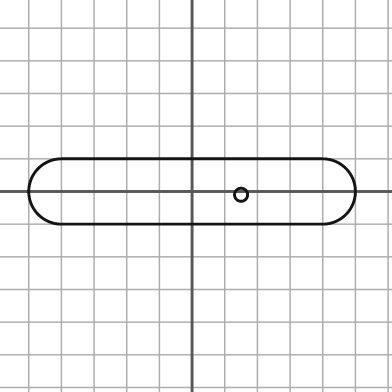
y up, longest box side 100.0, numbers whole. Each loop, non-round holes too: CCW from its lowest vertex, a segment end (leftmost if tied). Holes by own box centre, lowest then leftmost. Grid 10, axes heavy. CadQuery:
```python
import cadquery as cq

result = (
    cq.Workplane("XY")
    .moveTo(-40.0, -10.0)
    .lineTo(40.0, -10.0)
    .threePointArc((50.0, 0.0), (40.0, 10.0))
    .lineTo(-40.0, 10.0)
    .threePointArc((-50.0, 0.0), (-40.0, -10.0))
    .close()
    .moveTo(15.0, -1.0)
    .circle(2.0)
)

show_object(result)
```